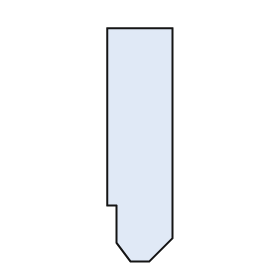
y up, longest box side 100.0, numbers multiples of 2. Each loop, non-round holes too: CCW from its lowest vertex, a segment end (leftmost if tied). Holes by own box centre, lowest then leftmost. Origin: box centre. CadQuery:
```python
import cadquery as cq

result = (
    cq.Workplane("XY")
    .moveTo(-4.0, -50.0)
    .lineTo(4.0, -50.0)
    .lineTo(14.0, -40.0)
    .lineTo(14.0, 50.0)
    .lineTo(-14.0, 50.0)
    .lineTo(-14.0, -26.0)
    .lineTo(-10.0, -26.0)
    .lineTo(-10.0, -42.0)
    .close()
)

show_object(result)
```